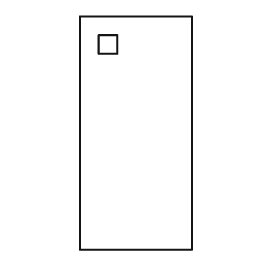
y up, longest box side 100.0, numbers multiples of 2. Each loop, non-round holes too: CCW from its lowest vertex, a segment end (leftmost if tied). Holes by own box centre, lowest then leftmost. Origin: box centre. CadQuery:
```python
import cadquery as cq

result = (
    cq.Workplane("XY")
    .moveTo(-24.0, -50.0)
    .lineTo(24.0, -50.0)
    .lineTo(24.0, 50.0)
    .lineTo(-24.0, 50.0)
    .close()
    .moveTo(-16.0, 34.0)
    .lineTo(-8.0, 34.0)
    .lineTo(-8.0, 42.0)
    .lineTo(-16.0, 42.0)
    .close()
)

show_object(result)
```